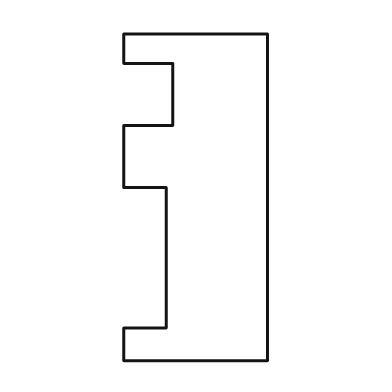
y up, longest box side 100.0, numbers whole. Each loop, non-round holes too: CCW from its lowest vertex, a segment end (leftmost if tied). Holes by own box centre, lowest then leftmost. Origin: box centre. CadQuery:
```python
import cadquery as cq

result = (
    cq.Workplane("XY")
    .moveTo(-22.0, -50.0)
    .lineTo(22.0, -50.0)
    .lineTo(22.0, 50.0)
    .lineTo(-22.0, 50.0)
    .lineTo(-22.0, 41.0)
    .lineTo(-7.0, 41.0)
    .lineTo(-7.0, 22.0)
    .lineTo(-22.0, 22.0)
    .lineTo(-22.0, 3.0)
    .lineTo(-9.0, 3.0)
    .lineTo(-9.0, -40.0)
    .lineTo(-22.0, -40.0)
    .close()
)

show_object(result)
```